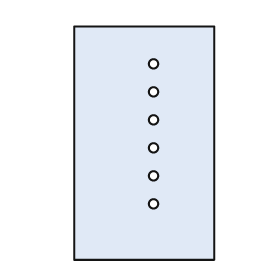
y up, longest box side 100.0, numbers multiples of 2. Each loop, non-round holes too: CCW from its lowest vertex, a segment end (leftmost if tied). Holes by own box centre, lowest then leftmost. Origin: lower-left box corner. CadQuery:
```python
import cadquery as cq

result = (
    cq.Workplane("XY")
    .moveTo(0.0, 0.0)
    .lineTo(60.0, 0.0)
    .lineTo(60.0, 100.0)
    .lineTo(0.0, 100.0)
    .close()
    .moveTo(34.0, 24.0)
    .circle(2.0)
    .moveTo(34.0, 36.0)
    .circle(2.0)
    .moveTo(34.0, 48.0)
    .circle(2.0)
    .moveTo(34.0, 60.0)
    .circle(2.0)
    .moveTo(34.0, 72.0)
    .circle(2.0)
    .moveTo(34.0, 84.0)
    .circle(2.0)
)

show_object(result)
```